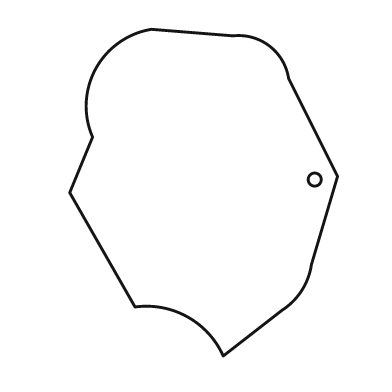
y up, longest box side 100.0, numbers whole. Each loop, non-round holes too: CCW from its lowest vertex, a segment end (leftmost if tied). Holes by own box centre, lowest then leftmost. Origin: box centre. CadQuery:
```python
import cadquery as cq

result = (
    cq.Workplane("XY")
    .moveTo(6.0, -50.0)
    .lineTo(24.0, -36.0)
    .threePointArc((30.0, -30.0), (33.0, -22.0))
    .lineTo(41.0, 5.0)
    .lineTo(26.0, 35.0)
    .threePointArc((20.0, 45.0), (9.0, 48.0))
    .lineTo(-16.0, 50.0)
    .threePointArc((-33.0, 38.0), (-34.0, 17.0))
    .lineTo(-41.0, 0.0)
    .lineTo(-21.0, -35.0)
    .threePointArc((-5.0, -38.0), (6.0, -50.0))
    .close()
    .moveTo(34.0, 4.0)
    .circle(2.0)
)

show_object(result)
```